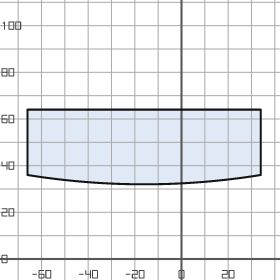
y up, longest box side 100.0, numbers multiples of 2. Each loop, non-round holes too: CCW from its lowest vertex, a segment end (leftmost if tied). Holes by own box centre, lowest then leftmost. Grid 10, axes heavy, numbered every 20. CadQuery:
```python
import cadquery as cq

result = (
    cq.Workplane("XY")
    .moveTo(-66.0, 36.0)
    .threePointArc((-16.0, 32.0), (34.0, 36.0))
    .lineTo(34.0, 64.0)
    .lineTo(-66.0, 64.0)
    .close()
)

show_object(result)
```